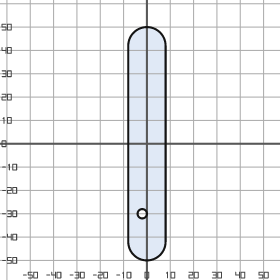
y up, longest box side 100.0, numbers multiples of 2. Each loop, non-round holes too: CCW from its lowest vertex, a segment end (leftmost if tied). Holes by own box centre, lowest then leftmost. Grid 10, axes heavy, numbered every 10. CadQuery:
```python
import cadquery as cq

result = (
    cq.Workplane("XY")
    .moveTo(-8.0, -42.0)
    .threePointArc((0.0, -50.0), (8.0, -42.0))
    .lineTo(8.0, 42.0)
    .threePointArc((0.0, 50.0), (-8.0, 42.0))
    .close()
    .moveTo(-2.0, -30.0)
    .circle(2.0)
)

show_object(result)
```